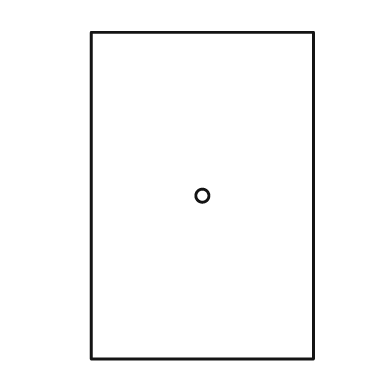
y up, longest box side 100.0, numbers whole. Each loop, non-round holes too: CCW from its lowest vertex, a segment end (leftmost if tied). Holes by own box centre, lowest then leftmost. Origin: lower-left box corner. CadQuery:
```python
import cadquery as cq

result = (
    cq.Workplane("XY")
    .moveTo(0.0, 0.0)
    .lineTo(68.0, 0.0)
    .lineTo(68.0, 100.0)
    .lineTo(0.0, 100.0)
    .close()
    .moveTo(34.0, 50.0)
    .circle(2.0)
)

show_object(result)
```